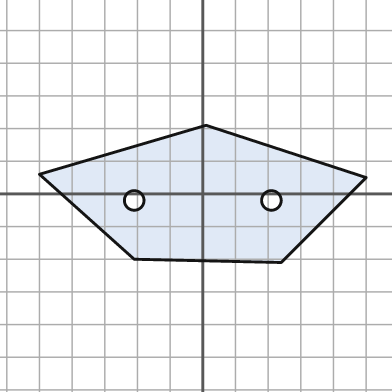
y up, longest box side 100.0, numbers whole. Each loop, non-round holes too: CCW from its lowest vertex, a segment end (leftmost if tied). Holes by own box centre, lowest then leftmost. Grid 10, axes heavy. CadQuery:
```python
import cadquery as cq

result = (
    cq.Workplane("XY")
    .moveTo(24.0, -21.0)
    .lineTo(50.0, 5.0)
    .lineTo(1.0, 21.0)
    .lineTo(-50.0, 6.0)
    .lineTo(-21.0, -20.0)
    .close()
    .moveTo(-21.0, -2.0)
    .circle(3.0)
    .moveTo(21.0, -2.0)
    .circle(3.0)
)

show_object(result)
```